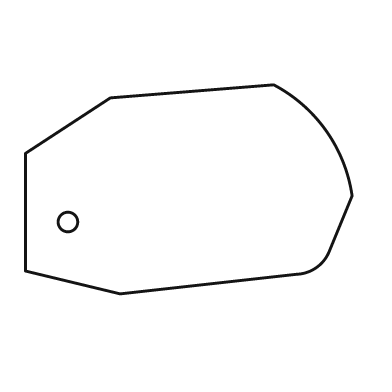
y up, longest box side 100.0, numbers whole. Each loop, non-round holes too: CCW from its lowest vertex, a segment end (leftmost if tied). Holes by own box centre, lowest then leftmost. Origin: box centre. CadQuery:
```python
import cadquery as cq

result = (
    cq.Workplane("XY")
    .moveTo(-21.0, -32.0)
    .lineTo(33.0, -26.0)
    .threePointArc((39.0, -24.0), (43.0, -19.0))
    .lineTo(50.0, -2.0)
    .threePointArc((42.0, 18.0), (26.0, 32.0))
    .lineTo(-24.0, 28.0)
    .lineTo(-50.0, 11.0)
    .lineTo(-50.0, -25.0)
    .close()
    .moveTo(-37.0, -10.0)
    .circle(3.0)
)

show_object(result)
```